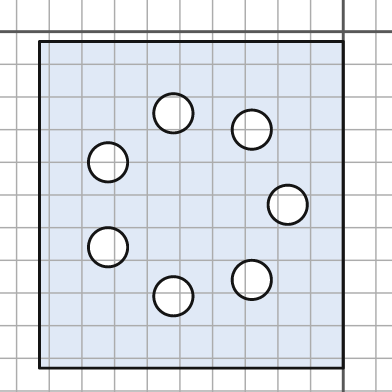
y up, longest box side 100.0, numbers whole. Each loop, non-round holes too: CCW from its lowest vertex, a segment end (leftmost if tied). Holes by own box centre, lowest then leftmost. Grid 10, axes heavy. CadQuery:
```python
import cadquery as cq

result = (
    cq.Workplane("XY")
    .moveTo(-93.0, -103.0)
    .lineTo(0.0, -103.0)
    .lineTo(0.0, -3.0)
    .lineTo(-93.0, -3.0)
    .close()
    .moveTo(-52.0, -81.0)
    .circle(6.0)
    .moveTo(-28.0, -76.0)
    .circle(6.0)
    .moveTo(-72.0, -66.0)
    .circle(6.0)
    .moveTo(-17.0, -53.0)
    .circle(6.0)
    .moveTo(-72.0, -40.0)
    .circle(6.0)
    .moveTo(-28.0, -30.0)
    .circle(6.0)
    .moveTo(-52.0, -25.0)
    .circle(6.0)
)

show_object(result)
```